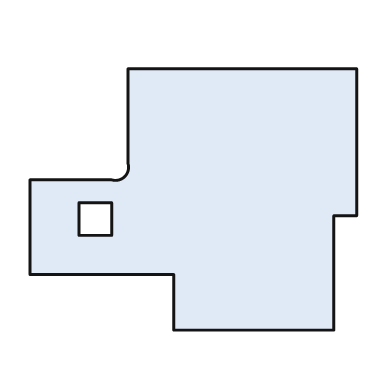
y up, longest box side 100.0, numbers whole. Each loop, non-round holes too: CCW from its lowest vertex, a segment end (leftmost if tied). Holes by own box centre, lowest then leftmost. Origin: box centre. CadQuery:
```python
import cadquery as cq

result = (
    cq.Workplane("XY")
    .moveTo(-6.0, -40.0)
    .lineTo(43.0, -40.0)
    .lineTo(43.0, -5.0)
    .lineTo(50.0, -5.0)
    .lineTo(50.0, 40.0)
    .lineTo(-20.0, 40.0)
    .lineTo(-20.0, 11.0)
    .threePointArc((-21.0, 7.0), (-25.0, 6.0))
    .lineTo(-50.0, 6.0)
    .lineTo(-50.0, -23.0)
    .lineTo(-6.0, -23.0)
    .close()
    .moveTo(-35.0, -11.0)
    .lineTo(-25.0, -11.0)
    .lineTo(-25.0, -1.0)
    .lineTo(-35.0, -1.0)
    .close()
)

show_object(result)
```